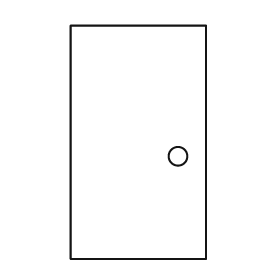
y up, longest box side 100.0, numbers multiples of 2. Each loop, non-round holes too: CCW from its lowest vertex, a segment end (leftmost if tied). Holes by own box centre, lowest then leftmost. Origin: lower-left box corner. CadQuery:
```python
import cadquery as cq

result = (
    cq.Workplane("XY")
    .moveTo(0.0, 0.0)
    .lineTo(58.0, 0.0)
    .lineTo(58.0, 100.0)
    .lineTo(0.0, 100.0)
    .close()
    .moveTo(46.0, 44.0)
    .circle(4.0)
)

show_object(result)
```